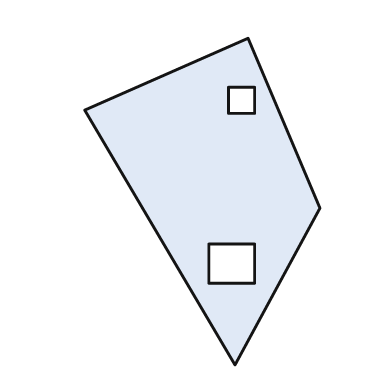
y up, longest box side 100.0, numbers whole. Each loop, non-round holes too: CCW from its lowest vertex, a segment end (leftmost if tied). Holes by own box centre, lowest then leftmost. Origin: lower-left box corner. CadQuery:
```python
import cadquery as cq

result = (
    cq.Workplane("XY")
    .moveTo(46.0, 0.0)
    .lineTo(72.0, 48.0)
    .lineTo(50.0, 100.0)
    .lineTo(0.0, 78.0)
    .close()
    .moveTo(38.0, 25.0)
    .lineTo(52.0, 25.0)
    .lineTo(52.0, 37.0)
    .lineTo(38.0, 37.0)
    .close()
    .moveTo(44.0, 77.0)
    .lineTo(52.0, 77.0)
    .lineTo(52.0, 85.0)
    .lineTo(44.0, 85.0)
    .close()
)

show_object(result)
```